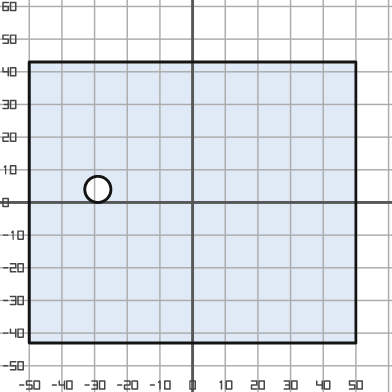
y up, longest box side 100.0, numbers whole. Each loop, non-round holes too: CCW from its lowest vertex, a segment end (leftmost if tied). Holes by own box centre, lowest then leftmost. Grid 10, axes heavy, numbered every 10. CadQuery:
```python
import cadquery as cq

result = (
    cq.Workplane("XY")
    .moveTo(-50.0, -43.0)
    .lineTo(50.0, -43.0)
    .lineTo(50.0, 43.0)
    .lineTo(-50.0, 43.0)
    .close()
    .moveTo(-29.0, 4.0)
    .circle(4.0)
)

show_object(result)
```